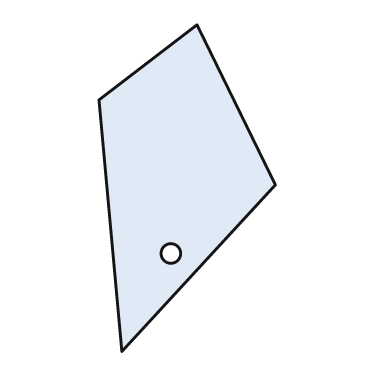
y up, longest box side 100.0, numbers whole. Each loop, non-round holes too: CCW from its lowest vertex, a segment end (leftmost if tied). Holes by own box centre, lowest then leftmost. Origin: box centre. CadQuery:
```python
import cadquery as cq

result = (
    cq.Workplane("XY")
    .moveTo(-20.0, -50.0)
    .lineTo(27.0, 1.0)
    .lineTo(3.0, 50.0)
    .lineTo(-27.0, 27.0)
    .close()
    .moveTo(-5.0, -20.0)
    .circle(3.0)
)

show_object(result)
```